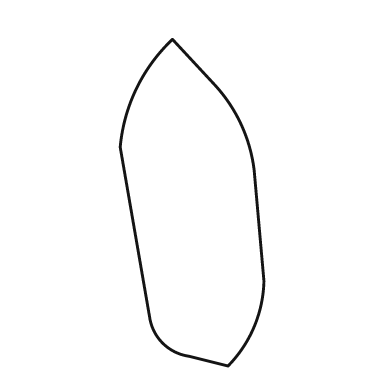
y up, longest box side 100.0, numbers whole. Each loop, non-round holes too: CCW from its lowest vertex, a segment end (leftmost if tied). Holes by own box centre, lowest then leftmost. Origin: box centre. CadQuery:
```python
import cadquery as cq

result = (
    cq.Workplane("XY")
    .moveTo(11.0, -50.0)
    .threePointArc((19.0, -38.0), (22.0, -24.0))
    .lineTo(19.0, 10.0)
    .threePointArc((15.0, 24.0), (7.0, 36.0))
    .lineTo(-6.0, 50.0)
    .threePointArc((-17.0, 35.0), (-22.0, 17.0))
    .lineTo(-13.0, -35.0)
    .threePointArc((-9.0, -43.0), (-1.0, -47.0))
    .close()
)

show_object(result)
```